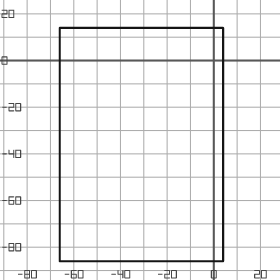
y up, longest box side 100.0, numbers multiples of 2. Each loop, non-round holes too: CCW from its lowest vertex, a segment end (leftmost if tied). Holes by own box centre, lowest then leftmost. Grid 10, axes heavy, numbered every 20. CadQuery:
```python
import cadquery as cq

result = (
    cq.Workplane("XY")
    .moveTo(-66.0, -86.0)
    .lineTo(4.0, -86.0)
    .lineTo(4.0, 14.0)
    .lineTo(-66.0, 14.0)
    .close()
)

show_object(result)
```